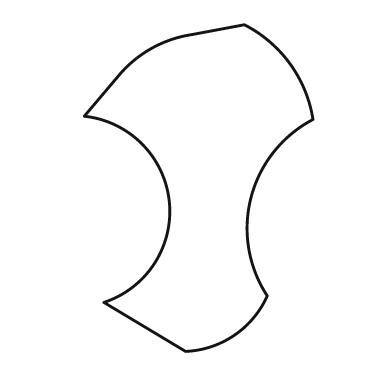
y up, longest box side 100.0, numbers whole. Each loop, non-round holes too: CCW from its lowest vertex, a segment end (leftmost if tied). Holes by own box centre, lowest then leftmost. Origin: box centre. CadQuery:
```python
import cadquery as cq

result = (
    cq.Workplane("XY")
    .moveTo(-4.0, -50.0)
    .threePointArc((11.0, -45.0), (21.0, -33.0))
    .threePointArc((16.0, -3.0), (35.0, 21.0))
    .threePointArc((28.0, 38.0), (14.0, 50.0))
    .lineTo(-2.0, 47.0)
    .threePointArc((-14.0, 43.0), (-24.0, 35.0))
    .lineTo(-35.0, 22.0)
    .threePointArc((-9.0, -4.0), (-29.0, -35.0))
    .close()
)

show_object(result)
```